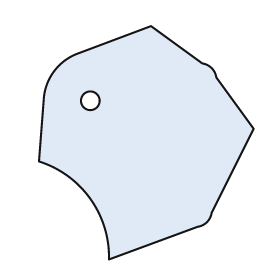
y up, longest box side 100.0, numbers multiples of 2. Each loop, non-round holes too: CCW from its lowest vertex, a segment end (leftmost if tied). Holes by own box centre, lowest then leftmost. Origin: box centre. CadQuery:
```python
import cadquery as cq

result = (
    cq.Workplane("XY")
    .moveTo(-16.0, -50.0)
    .lineTo(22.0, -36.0)
    .threePointArc((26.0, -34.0), (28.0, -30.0))
    .lineTo(46.0, 6.0)
    .lineTo(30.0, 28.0)
    .threePointArc((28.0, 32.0), (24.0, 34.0))
    .lineTo(2.0, 50.0)
    .lineTo(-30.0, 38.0)
    .threePointArc((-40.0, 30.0), (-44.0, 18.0))
    .lineTo(-46.0, -8.0)
    .threePointArc((-24.0, -24.0), (-16.0, -50.0))
    .close()
    .moveTo(-24.0, 18.0)
    .circle(4.0)
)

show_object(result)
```